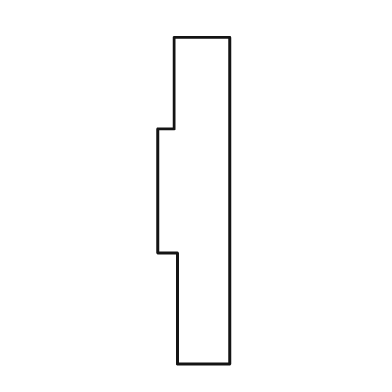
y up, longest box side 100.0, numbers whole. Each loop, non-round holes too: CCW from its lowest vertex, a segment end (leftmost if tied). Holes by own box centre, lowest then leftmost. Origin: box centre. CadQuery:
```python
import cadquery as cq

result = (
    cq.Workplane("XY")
    .moveTo(-5.0, -50.0)
    .lineTo(11.0, -50.0)
    .lineTo(11.0, 50.0)
    .lineTo(-6.0, 50.0)
    .lineTo(-6.0, 22.0)
    .lineTo(-11.0, 22.0)
    .lineTo(-11.0, -16.0)
    .lineTo(-5.0, -16.0)
    .close()
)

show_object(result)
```